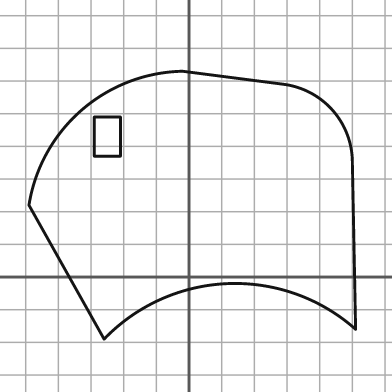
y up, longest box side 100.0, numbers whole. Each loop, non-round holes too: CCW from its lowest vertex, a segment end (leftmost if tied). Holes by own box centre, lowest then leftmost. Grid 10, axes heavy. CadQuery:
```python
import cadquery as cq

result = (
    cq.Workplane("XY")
    .moveTo(-26.0, -19.0)
    .threePointArc((12.0, -2.0), (51.0, -16.0))
    .lineTo(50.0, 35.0)
    .threePointArc((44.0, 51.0), (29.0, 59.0))
    .lineTo(-2.0, 63.0)
    .threePointArc((-33.0, 51.0), (-49.0, 22.0))
    .close()
    .moveTo(-29.0, 37.0)
    .lineTo(-21.0, 37.0)
    .lineTo(-21.0, 49.0)
    .lineTo(-29.0, 49.0)
    .close()
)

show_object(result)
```